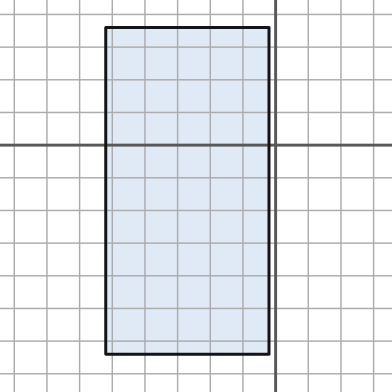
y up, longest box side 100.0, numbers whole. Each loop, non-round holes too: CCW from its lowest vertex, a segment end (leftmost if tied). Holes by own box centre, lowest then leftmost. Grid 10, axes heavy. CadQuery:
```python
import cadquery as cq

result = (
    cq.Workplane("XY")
    .moveTo(-52.0, -64.0)
    .lineTo(-2.0, -64.0)
    .lineTo(-2.0, 36.0)
    .lineTo(-52.0, 36.0)
    .close()
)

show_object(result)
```